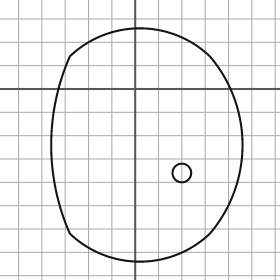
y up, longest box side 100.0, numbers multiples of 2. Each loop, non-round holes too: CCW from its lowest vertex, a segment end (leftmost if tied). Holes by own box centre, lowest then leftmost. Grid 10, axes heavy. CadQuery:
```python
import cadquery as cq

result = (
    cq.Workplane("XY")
    .moveTo(-28.0, -62.0)
    .threePointArc((2.0, -74.0), (32.0, -62.0))
    .threePointArc((46.0, -24.0), (32.0, 14.0))
    .threePointArc((2.0, 26.0), (-28.0, 14.0))
    .threePointArc((-36.0, -24.0), (-28.0, -62.0))
    .close()
    .moveTo(20.0, -36.0)
    .circle(4.0)
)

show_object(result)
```